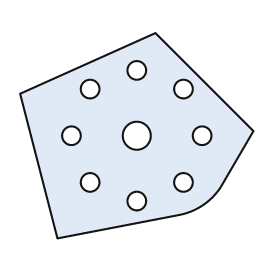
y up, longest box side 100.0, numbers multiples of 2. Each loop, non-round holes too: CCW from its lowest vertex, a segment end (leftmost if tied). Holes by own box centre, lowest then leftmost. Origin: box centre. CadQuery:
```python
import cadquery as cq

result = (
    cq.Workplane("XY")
    .moveTo(-34.0, -44.0)
    .lineTo(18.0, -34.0)
    .threePointArc((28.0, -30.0), (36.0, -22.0))
    .lineTo(50.0, 2.0)
    .lineTo(8.0, 44.0)
    .lineTo(-50.0, 18.0)
    .close()
    .moveTo(0.0, -28.0)
    .circle(4.0)
    .moveTo(-20.0, -20.0)
    .circle(4.0)
    .moveTo(20.0, -20.0)
    .circle(4.0)
    .moveTo(-28.0, 0.0)
    .circle(4.0)
    .moveTo(0.0, 0.0)
    .circle(6.0)
    .moveTo(28.0, 0.0)
    .circle(4.0)
    .moveTo(-20.0, 20.0)
    .circle(4.0)
    .moveTo(20.0, 20.0)
    .circle(4.0)
    .moveTo(0.0, 28.0)
    .circle(4.0)
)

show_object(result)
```